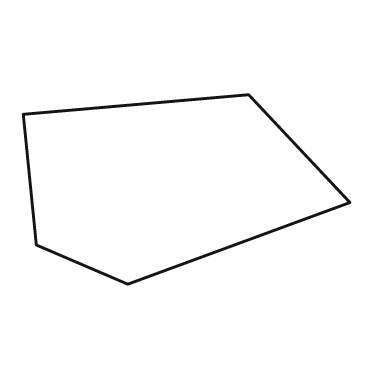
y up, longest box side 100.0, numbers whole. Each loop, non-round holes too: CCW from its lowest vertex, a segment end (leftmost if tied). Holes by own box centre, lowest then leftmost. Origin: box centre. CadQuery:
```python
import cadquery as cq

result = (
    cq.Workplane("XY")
    .moveTo(-18.0, -29.0)
    .lineTo(50.0, -4.0)
    .lineTo(19.0, 29.0)
    .lineTo(-50.0, 23.0)
    .lineTo(-46.0, -17.0)
    .close()
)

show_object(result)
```